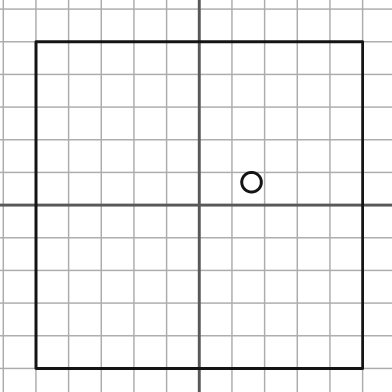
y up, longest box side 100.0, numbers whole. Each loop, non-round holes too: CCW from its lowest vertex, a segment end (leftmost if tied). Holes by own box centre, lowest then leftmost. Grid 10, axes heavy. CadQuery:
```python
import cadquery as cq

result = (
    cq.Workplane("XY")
    .moveTo(-50.0, -50.0)
    .lineTo(50.0, -50.0)
    .lineTo(50.0, 50.0)
    .lineTo(-50.0, 50.0)
    .close()
    .moveTo(16.0, 7.0)
    .circle(3.0)
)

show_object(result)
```